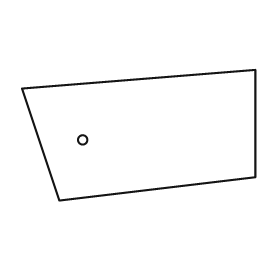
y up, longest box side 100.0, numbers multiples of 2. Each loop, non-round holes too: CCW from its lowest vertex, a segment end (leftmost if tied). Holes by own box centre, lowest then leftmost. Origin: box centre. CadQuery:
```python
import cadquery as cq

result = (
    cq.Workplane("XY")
    .moveTo(-34.0, -28.0)
    .lineTo(50.0, -18.0)
    .lineTo(50.0, 28.0)
    .lineTo(-50.0, 20.0)
    .close()
    .moveTo(-24.0, -2.0)
    .circle(2.0)
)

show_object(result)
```